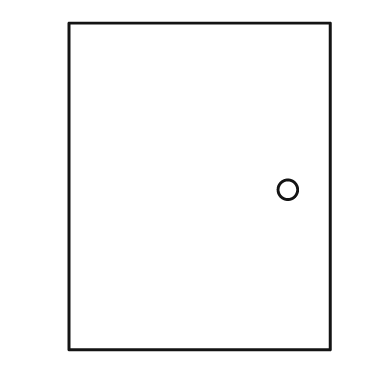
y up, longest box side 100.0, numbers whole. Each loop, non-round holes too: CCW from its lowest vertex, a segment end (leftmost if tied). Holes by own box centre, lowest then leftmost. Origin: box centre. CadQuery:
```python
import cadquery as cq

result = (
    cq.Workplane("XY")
    .moveTo(-40.0, -50.0)
    .lineTo(40.0, -50.0)
    .lineTo(40.0, 50.0)
    .lineTo(-40.0, 50.0)
    .close()
    .moveTo(27.0, -1.0)
    .circle(3.0)
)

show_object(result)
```